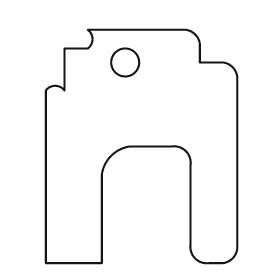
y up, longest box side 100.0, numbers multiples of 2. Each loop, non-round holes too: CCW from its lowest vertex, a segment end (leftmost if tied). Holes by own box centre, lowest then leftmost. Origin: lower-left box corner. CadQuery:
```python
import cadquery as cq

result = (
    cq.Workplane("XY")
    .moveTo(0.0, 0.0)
    .lineTo(24.0, 0.0)
    .lineTo(24.0, 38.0)
    .threePointArc((28.0, 46.0), (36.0, 50.0))
    .lineTo(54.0, 50.0)
    .threePointArc((60.0, 48.0), (62.0, 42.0))
    .lineTo(62.0, 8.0)
    .threePointArc((64.0, 2.0), (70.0, 0.0))
    .lineTo(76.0, 0.0)
    .threePointArc((80.0, 2.0), (82.0, 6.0))
    .lineTo(82.0, 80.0)
    .threePointArc((80.0, 84.0), (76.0, 86.0))
    .lineTo(66.0, 86.0)
    .lineTo(66.0, 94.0)
    .threePointArc((64.0, 98.0), (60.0, 100.0))
    .lineTo(18.0, 100.0)
    .threePointArc((20.0, 96.0), (18.0, 92.0))
    .lineTo(8.0, 92.0)
    .lineTo(8.0, 74.0)
    .threePointArc((4.0, 76.0), (0.0, 74.0))
    .close()
    .moveTo(34.0, 86.0)
    .circle(6.0)
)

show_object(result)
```